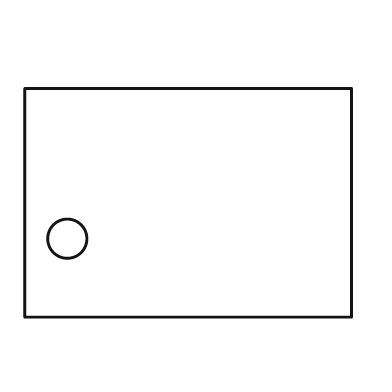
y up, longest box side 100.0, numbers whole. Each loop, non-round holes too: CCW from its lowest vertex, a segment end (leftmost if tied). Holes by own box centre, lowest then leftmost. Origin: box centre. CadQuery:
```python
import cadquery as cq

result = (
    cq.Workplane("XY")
    .moveTo(-50.0, -35.0)
    .lineTo(50.0, -35.0)
    .lineTo(50.0, 35.0)
    .lineTo(-50.0, 35.0)
    .close()
    .moveTo(-37.0, -11.0)
    .circle(6.0)
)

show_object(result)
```